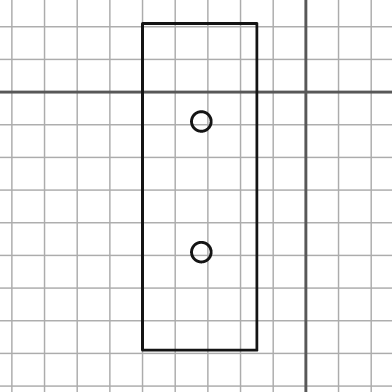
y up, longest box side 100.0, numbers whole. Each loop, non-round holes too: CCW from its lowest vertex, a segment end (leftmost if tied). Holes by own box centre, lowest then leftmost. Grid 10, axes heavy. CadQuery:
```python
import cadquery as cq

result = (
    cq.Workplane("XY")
    .moveTo(-50.0, -79.0)
    .lineTo(-15.0, -79.0)
    .lineTo(-15.0, 21.0)
    .lineTo(-50.0, 21.0)
    .close()
    .moveTo(-32.0, -49.0)
    .circle(3.0)
    .moveTo(-32.0, -9.0)
    .circle(3.0)
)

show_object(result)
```